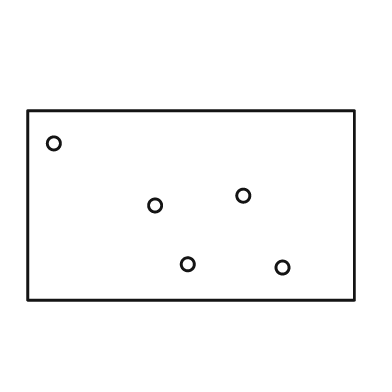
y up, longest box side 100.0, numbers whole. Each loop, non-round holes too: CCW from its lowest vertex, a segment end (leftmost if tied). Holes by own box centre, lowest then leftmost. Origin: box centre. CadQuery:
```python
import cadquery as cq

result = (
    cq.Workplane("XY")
    .moveTo(-50.0, -29.0)
    .lineTo(50.0, -29.0)
    .lineTo(50.0, 29.0)
    .lineTo(-50.0, 29.0)
    .close()
    .moveTo(28.0, -19.0)
    .circle(2.0)
    .moveTo(-1.0, -18.0)
    .circle(2.0)
    .moveTo(-11.0, 0.0)
    .circle(2.0)
    .moveTo(16.0, 3.0)
    .circle(2.0)
    .moveTo(-42.0, 19.0)
    .circle(2.0)
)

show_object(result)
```